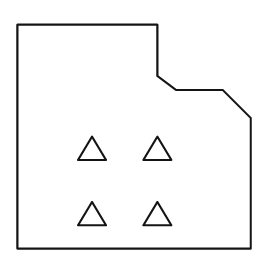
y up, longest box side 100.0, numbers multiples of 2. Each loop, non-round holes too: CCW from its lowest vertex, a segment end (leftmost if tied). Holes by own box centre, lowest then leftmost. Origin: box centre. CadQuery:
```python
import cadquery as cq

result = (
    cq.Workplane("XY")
    .moveTo(-50.0, -48.0)
    .lineTo(50.0, -48.0)
    .lineTo(50.0, 8.0)
    .lineTo(38.0, 20.0)
    .lineTo(18.0, 20.0)
    .lineTo(10.0, 26.0)
    .lineTo(10.0, 48.0)
    .lineTo(-50.0, 48.0)
    .close()
    .moveTo(-24.0, -38.0)
    .lineTo(-12.0, -38.0)
    .lineTo(-18.0, -28.0)
    .close()
    .moveTo(4.0, -38.0)
    .lineTo(16.0, -38.0)
    .lineTo(10.0, -28.0)
    .close()
    .moveTo(-24.0, -10.0)
    .lineTo(-12.0, -10.0)
    .lineTo(-18.0, 0.0)
    .close()
    .moveTo(4.0, -10.0)
    .lineTo(16.0, -10.0)
    .lineTo(10.0, 0.0)
    .close()
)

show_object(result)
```